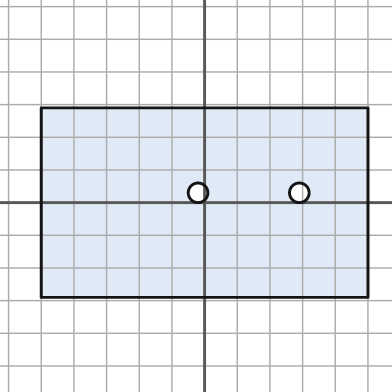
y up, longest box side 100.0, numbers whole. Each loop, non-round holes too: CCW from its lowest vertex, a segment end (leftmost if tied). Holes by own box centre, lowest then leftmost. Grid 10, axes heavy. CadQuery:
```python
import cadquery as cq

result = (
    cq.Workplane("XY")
    .moveTo(-50.0, -29.0)
    .lineTo(50.0, -29.0)
    .lineTo(50.0, 29.0)
    .lineTo(-50.0, 29.0)
    .close()
    .moveTo(-2.0, 3.0)
    .circle(3.0)
    .moveTo(29.0, 3.0)
    .circle(3.0)
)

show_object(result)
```